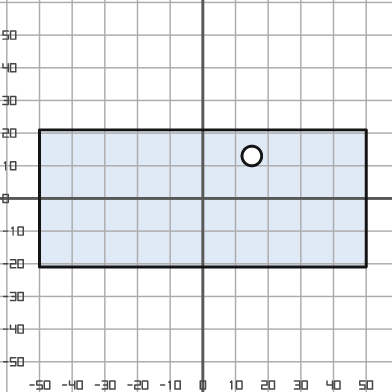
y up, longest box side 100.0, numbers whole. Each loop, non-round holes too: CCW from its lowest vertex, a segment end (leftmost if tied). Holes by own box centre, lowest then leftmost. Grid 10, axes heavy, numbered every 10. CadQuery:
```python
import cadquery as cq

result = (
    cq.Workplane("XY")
    .moveTo(-50.0, -21.0)
    .lineTo(50.0, -21.0)
    .lineTo(50.0, 21.0)
    .lineTo(-50.0, 21.0)
    .close()
    .moveTo(15.0, 13.0)
    .circle(3.0)
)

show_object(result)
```